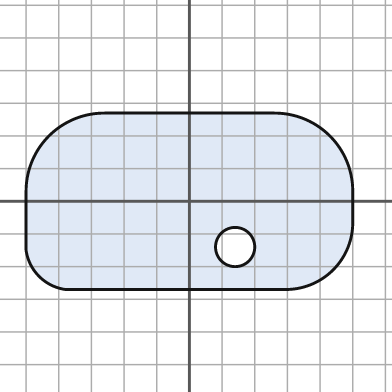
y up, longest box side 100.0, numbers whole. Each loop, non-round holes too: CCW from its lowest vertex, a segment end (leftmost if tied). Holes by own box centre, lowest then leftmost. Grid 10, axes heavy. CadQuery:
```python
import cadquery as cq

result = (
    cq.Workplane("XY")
    .moveTo(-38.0, -27.0)
    .lineTo(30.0, -27.0)
    .threePointArc((44.0, -21.0), (50.0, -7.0))
    .lineTo(50.0, 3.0)
    .threePointArc((43.0, 20.0), (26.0, 27.0))
    .lineTo(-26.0, 27.0)
    .threePointArc((-43.0, 20.0), (-50.0, 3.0))
    .lineTo(-50.0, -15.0)
    .threePointArc((-46.0, -23.0), (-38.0, -27.0))
    .close()
    .moveTo(14.0, -14.0)
    .circle(6.0)
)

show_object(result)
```